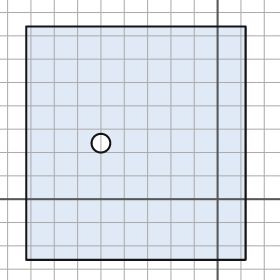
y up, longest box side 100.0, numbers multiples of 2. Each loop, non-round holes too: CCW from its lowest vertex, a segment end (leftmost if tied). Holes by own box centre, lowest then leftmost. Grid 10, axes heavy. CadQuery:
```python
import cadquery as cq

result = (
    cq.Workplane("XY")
    .moveTo(-82.0, -26.0)
    .lineTo(12.0, -26.0)
    .lineTo(12.0, 74.0)
    .lineTo(-82.0, 74.0)
    .close()
    .moveTo(-50.0, 24.0)
    .circle(4.0)
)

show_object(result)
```